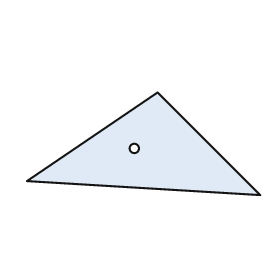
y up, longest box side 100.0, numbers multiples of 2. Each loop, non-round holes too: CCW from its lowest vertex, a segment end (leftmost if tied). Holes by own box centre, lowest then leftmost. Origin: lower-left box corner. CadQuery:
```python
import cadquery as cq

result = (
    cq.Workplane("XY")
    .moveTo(100.0, 0.0)
    .lineTo(56.0, 44.0)
    .lineTo(0.0, 6.0)
    .close()
    .moveTo(46.0, 20.0)
    .circle(2.0)
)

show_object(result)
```